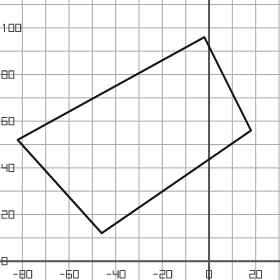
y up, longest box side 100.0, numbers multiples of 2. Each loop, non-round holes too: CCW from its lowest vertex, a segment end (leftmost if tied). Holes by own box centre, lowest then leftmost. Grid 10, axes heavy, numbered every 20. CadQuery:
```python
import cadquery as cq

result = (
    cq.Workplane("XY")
    .moveTo(-46.0, 12.0)
    .lineTo(18.0, 56.0)
    .lineTo(-2.0, 96.0)
    .lineTo(-82.0, 52.0)
    .close()
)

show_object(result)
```